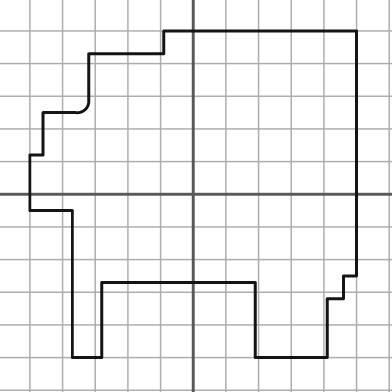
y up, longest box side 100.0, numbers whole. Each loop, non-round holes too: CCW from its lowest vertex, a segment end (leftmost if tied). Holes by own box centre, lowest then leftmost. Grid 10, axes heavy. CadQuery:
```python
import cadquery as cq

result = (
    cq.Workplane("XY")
    .moveTo(-37.0, -50.0)
    .lineTo(-28.0, -50.0)
    .lineTo(-28.0, -27.0)
    .lineTo(19.0, -27.0)
    .lineTo(19.0, -50.0)
    .lineTo(41.0, -50.0)
    .lineTo(41.0, -32.0)
    .lineTo(46.0, -32.0)
    .lineTo(46.0, -25.0)
    .lineTo(50.0, -25.0)
    .lineTo(50.0, 50.0)
    .lineTo(-9.0, 50.0)
    .lineTo(-9.0, 43.0)
    .lineTo(-32.0, 43.0)
    .lineTo(-32.0, 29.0)
    .threePointArc((-33.0, 26.0), (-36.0, 25.0))
    .lineTo(-46.0, 25.0)
    .lineTo(-46.0, 12.0)
    .lineTo(-50.0, 12.0)
    .lineTo(-50.0, -5.0)
    .lineTo(-37.0, -5.0)
    .close()
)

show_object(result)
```